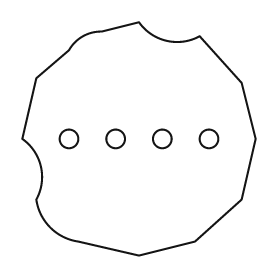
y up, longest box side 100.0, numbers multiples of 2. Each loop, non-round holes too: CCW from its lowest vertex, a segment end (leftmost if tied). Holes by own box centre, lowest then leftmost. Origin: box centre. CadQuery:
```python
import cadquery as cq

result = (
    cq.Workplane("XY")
    .moveTo(0.0, -50.0)
    .lineTo(24.0, -44.0)
    .lineTo(44.0, -26.0)
    .lineTo(50.0, 0.0)
    .lineTo(44.0, 24.0)
    .lineTo(26.0, 44.0)
    .threePointArc((12.0, 42.0), (0.0, 50.0))
    .lineTo(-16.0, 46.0)
    .threePointArc((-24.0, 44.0), (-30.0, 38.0))
    .lineTo(-44.0, 26.0)
    .lineTo(-50.0, 0.0)
    .threePointArc((-42.0, -12.0), (-44.0, -26.0))
    .threePointArc((-38.0, -38.0), (-26.0, -44.0))
    .close()
    .moveTo(-30.0, 0.0)
    .circle(4.0)
    .moveTo(-10.0, 0.0)
    .circle(4.0)
    .moveTo(10.0, 0.0)
    .circle(4.0)
    .moveTo(30.0, 0.0)
    .circle(4.0)
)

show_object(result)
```